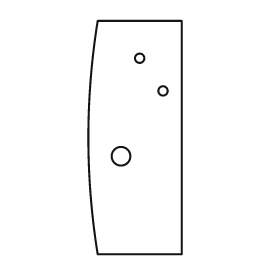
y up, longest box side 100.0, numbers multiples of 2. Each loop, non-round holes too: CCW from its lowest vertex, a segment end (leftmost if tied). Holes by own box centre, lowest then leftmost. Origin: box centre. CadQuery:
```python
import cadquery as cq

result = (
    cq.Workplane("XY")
    .moveTo(-16.0, -50.0)
    .lineTo(20.0, -50.0)
    .lineTo(20.0, 50.0)
    .lineTo(-16.0, 50.0)
    .threePointArc((-20.0, 0.0), (-16.0, -50.0))
    .close()
    .moveTo(-6.0, -8.0)
    .circle(4.0)
    .moveTo(12.0, 20.0)
    .circle(2.0)
    .moveTo(2.0, 34.0)
    .circle(2.0)
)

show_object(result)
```